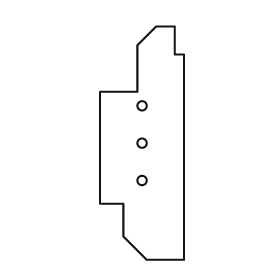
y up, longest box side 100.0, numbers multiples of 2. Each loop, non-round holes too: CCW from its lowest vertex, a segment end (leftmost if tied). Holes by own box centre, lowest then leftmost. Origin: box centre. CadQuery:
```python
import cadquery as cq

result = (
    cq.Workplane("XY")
    .moveTo(2.0, -50.0)
    .lineTo(18.0, -50.0)
    .lineTo(18.0, 38.0)
    .lineTo(14.0, 38.0)
    .lineTo(14.0, 50.0)
    .lineTo(6.0, 50.0)
    .lineTo(-2.0, 42.0)
    .lineTo(-2.0, 22.0)
    .lineTo(-18.0, 22.0)
    .lineTo(-18.0, -26.0)
    .lineTo(-8.0, -26.0)
    .lineTo(-8.0, -40.0)
    .close()
    .moveTo(0.0, -16.0)
    .circle(2.0)
    .moveTo(0.0, 0.0)
    .circle(2.0)
    .moveTo(0.0, 16.0)
    .circle(2.0)
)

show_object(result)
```